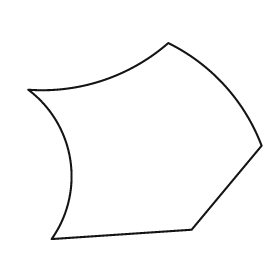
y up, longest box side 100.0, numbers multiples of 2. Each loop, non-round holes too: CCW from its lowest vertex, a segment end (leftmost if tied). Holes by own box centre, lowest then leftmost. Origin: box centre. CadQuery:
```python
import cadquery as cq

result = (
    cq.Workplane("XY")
    .moveTo(-40.0, -42.0)
    .lineTo(20.0, -38.0)
    .lineTo(50.0, -2.0)
    .threePointArc((34.0, 24.0), (10.0, 42.0))
    .threePointArc((-18.0, 26.0), (-50.0, 22.0))
    .threePointArc((-32.0, -8.0), (-40.0, -42.0))
    .close()
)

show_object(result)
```